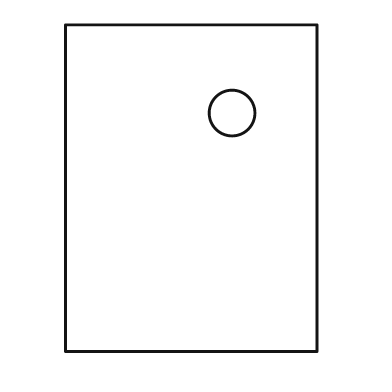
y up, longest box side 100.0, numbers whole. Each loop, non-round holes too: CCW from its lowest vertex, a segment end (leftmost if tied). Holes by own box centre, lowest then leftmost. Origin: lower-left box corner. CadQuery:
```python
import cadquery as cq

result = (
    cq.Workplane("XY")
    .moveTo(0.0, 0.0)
    .lineTo(77.0, 0.0)
    .lineTo(77.0, 100.0)
    .lineTo(0.0, 100.0)
    .close()
    .moveTo(51.0, 73.0)
    .circle(7.0)
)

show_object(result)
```